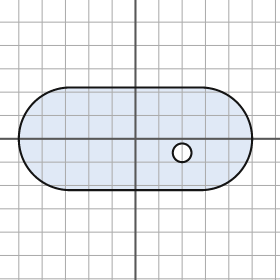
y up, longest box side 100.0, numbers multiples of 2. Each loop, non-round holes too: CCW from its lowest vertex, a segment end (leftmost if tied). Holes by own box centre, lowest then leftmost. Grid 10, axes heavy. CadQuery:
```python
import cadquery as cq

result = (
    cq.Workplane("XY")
    .moveTo(-28.0, -22.0)
    .lineTo(28.0, -22.0)
    .threePointArc((50.0, 0.0), (28.0, 22.0))
    .lineTo(-28.0, 22.0)
    .threePointArc((-50.0, 0.0), (-28.0, -22.0))
    .close()
    .moveTo(20.0, -6.0)
    .circle(4.0)
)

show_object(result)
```